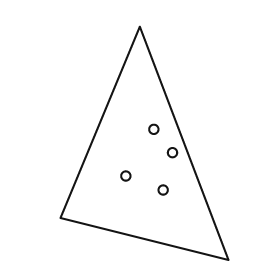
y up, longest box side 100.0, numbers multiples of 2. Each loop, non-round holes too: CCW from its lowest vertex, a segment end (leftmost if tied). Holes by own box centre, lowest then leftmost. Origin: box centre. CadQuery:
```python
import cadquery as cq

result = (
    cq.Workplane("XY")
    .moveTo(36.0, -50.0)
    .lineTo(-2.0, 50.0)
    .lineTo(-36.0, -32.0)
    .close()
    .moveTo(8.0, -20.0)
    .circle(2.0)
    .moveTo(-8.0, -14.0)
    .circle(2.0)
    .moveTo(12.0, -4.0)
    .circle(2.0)
    .moveTo(4.0, 6.0)
    .circle(2.0)
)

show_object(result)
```